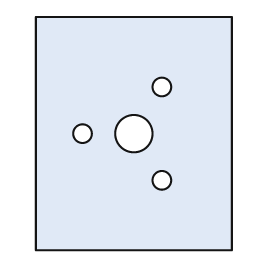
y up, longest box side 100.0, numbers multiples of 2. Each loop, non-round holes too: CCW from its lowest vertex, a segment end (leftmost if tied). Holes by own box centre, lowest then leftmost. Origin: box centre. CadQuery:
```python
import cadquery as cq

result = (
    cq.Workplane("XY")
    .moveTo(-42.0, -50.0)
    .lineTo(42.0, -50.0)
    .lineTo(42.0, 50.0)
    .lineTo(-42.0, 50.0)
    .close()
    .moveTo(12.0, -20.0)
    .circle(4.0)
    .moveTo(-22.0, 0.0)
    .circle(4.0)
    .moveTo(0.0, 0.0)
    .circle(8.0)
    .moveTo(12.0, 20.0)
    .circle(4.0)
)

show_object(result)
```